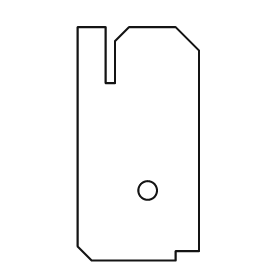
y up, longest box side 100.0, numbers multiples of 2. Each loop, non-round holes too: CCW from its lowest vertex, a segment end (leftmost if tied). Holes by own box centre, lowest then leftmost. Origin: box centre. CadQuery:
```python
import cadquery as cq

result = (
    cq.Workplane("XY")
    .moveTo(-20.0, -50.0)
    .lineTo(16.0, -50.0)
    .lineTo(16.0, -46.0)
    .lineTo(26.0, -46.0)
    .lineTo(26.0, 40.0)
    .lineTo(16.0, 50.0)
    .lineTo(-4.0, 50.0)
    .lineTo(-10.0, 44.0)
    .lineTo(-10.0, 26.0)
    .lineTo(-14.0, 26.0)
    .lineTo(-14.0, 50.0)
    .lineTo(-26.0, 50.0)
    .lineTo(-26.0, -44.0)
    .close()
    .moveTo(4.0, -20.0)
    .circle(4.0)
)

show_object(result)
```